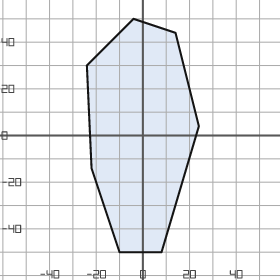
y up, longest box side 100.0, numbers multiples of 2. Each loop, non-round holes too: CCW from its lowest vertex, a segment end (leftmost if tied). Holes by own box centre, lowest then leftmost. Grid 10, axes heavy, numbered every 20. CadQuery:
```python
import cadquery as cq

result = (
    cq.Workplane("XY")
    .moveTo(-10.0, -50.0)
    .lineTo(8.0, -50.0)
    .lineTo(24.0, 4.0)
    .lineTo(14.0, 44.0)
    .lineTo(-4.0, 50.0)
    .lineTo(-24.0, 30.0)
    .lineTo(-22.0, -14.0)
    .close()
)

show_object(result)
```